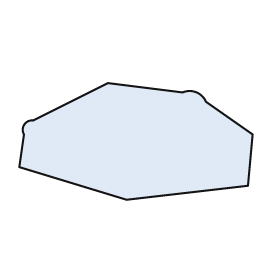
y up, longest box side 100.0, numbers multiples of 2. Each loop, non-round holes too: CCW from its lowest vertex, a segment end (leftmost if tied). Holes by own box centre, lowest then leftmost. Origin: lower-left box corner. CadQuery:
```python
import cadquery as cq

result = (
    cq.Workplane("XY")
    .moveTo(46.0, 0.0)
    .lineTo(98.0, 6.0)
    .lineTo(100.0, 28.0)
    .lineTo(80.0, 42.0)
    .threePointArc((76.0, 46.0), (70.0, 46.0))
    .lineTo(38.0, 50.0)
    .lineTo(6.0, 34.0)
    .threePointArc((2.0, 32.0), (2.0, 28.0))
    .lineTo(0.0, 14.0)
    .close()
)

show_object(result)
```